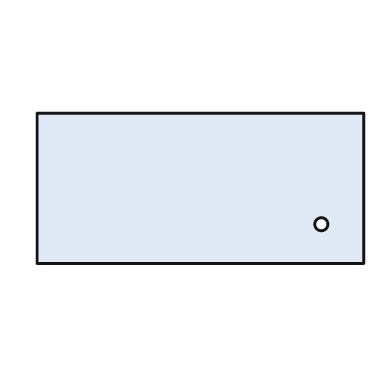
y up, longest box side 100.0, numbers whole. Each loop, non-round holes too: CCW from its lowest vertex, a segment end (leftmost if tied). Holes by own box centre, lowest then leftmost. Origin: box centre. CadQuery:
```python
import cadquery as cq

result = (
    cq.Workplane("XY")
    .moveTo(-50.0, -23.0)
    .lineTo(50.0, -23.0)
    .lineTo(50.0, 23.0)
    .lineTo(-50.0, 23.0)
    .close()
    .moveTo(37.0, -11.0)
    .circle(2.0)
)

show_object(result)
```